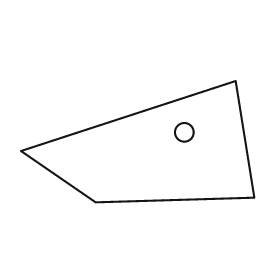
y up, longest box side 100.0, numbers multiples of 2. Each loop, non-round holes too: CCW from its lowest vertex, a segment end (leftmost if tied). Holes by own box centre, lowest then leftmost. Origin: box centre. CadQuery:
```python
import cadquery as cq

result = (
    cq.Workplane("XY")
    .moveTo(-18.0, -26.0)
    .lineTo(50.0, -24.0)
    .lineTo(42.0, 26.0)
    .lineTo(-50.0, -4.0)
    .close()
    .moveTo(20.0, 4.0)
    .circle(4.0)
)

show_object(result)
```